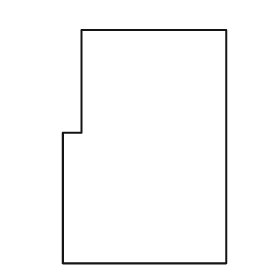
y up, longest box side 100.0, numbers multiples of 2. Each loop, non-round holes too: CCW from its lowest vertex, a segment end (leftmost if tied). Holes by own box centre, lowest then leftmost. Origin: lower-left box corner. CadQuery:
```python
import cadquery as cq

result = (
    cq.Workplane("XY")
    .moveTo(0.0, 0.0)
    .lineTo(70.0, 0.0)
    .lineTo(70.0, 100.0)
    .lineTo(8.0, 100.0)
    .lineTo(8.0, 56.0)
    .lineTo(0.0, 56.0)
    .close()
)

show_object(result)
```